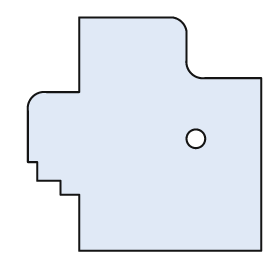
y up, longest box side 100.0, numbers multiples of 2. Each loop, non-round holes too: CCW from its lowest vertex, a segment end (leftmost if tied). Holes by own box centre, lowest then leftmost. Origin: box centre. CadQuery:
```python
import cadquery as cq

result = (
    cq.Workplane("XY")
    .moveTo(-28.0, -50.0)
    .lineTo(50.0, -50.0)
    .lineTo(50.0, 24.0)
    .lineTo(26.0, 24.0)
    .threePointArc((20.0, 26.0), (18.0, 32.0))
    .lineTo(18.0, 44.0)
    .threePointArc((16.0, 48.0), (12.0, 50.0))
    .lineTo(-28.0, 50.0)
    .lineTo(-28.0, 18.0)
    .lineTo(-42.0, 18.0)
    .threePointArc((-48.0, 16.0), (-50.0, 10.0))
    .lineTo(-50.0, -12.0)
    .lineTo(-46.0, -12.0)
    .lineTo(-46.0, -20.0)
    .lineTo(-36.0, -20.0)
    .lineTo(-36.0, -26.0)
    .lineTo(-28.0, -26.0)
    .close()
    .moveTo(22.0, -2.0)
    .circle(4.0)
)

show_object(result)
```